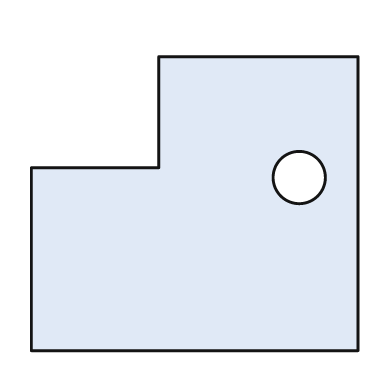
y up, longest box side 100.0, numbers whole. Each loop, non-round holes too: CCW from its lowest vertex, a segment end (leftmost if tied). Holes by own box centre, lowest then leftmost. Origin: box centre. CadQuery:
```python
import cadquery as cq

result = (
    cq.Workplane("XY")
    .moveTo(-50.0, -45.0)
    .lineTo(50.0, -45.0)
    .lineTo(50.0, 45.0)
    .lineTo(-11.0, 45.0)
    .lineTo(-11.0, 11.0)
    .lineTo(-50.0, 11.0)
    .close()
    .moveTo(32.0, 8.0)
    .circle(8.0)
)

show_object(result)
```